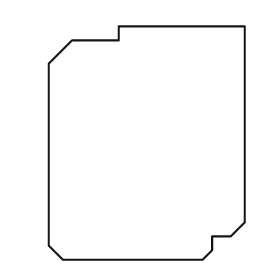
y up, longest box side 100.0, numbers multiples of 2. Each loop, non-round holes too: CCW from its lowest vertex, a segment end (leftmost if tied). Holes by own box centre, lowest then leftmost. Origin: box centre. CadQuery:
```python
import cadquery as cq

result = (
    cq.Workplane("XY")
    .moveTo(-36.0, -50.0)
    .lineTo(24.0, -50.0)
    .lineTo(28.0, -46.0)
    .lineTo(28.0, -40.0)
    .lineTo(36.0, -40.0)
    .lineTo(42.0, -34.0)
    .lineTo(42.0, 50.0)
    .lineTo(-12.0, 50.0)
    .lineTo(-12.0, 44.0)
    .lineTo(-32.0, 44.0)
    .lineTo(-42.0, 34.0)
    .lineTo(-42.0, -44.0)
    .close()
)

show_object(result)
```